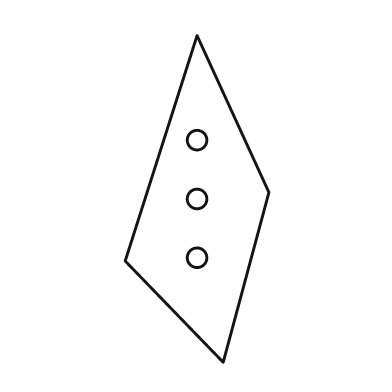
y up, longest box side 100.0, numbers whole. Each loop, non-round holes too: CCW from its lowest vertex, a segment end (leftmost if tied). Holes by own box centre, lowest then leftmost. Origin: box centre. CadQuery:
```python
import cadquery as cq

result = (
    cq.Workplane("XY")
    .moveTo(8.0, -50.0)
    .lineTo(22.0, 2.0)
    .lineTo(0.0, 50.0)
    .lineTo(-22.0, -19.0)
    .close()
    .moveTo(0.0, -18.0)
    .circle(3.0)
    .moveTo(0.0, 0.0)
    .circle(3.0)
    .moveTo(0.0, 18.0)
    .circle(3.0)
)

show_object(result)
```